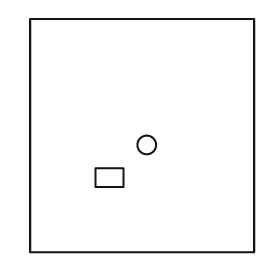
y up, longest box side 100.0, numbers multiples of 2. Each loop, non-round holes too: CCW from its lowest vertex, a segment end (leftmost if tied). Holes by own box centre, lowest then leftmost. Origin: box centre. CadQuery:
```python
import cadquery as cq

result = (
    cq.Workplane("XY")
    .moveTo(-48.0, -50.0)
    .lineTo(48.0, -50.0)
    .lineTo(48.0, 50.0)
    .lineTo(-48.0, 50.0)
    .close()
    .moveTo(-20.0, -22.0)
    .lineTo(-8.0, -22.0)
    .lineTo(-8.0, -14.0)
    .lineTo(-20.0, -14.0)
    .close()
    .moveTo(2.0, -4.0)
    .circle(4.0)
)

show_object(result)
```